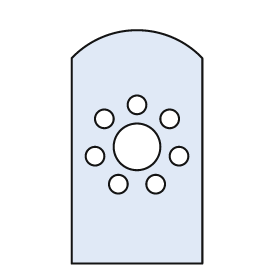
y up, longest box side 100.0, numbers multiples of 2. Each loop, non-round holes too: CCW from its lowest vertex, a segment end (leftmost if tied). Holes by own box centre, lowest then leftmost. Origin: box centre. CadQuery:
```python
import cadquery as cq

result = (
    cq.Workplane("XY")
    .moveTo(-28.0, -50.0)
    .lineTo(28.0, -50.0)
    .lineTo(28.0, 38.0)
    .threePointArc((0.0, 50.0), (-28.0, 38.0))
    .close()
    .moveTo(-8.0, -16.0)
    .circle(4.0)
    .moveTo(8.0, -16.0)
    .circle(4.0)
    .moveTo(-18.0, -4.0)
    .circle(4.0)
    .moveTo(18.0, -4.0)
    .circle(4.0)
    .moveTo(0.0, 0.0)
    .circle(10.0)
    .moveTo(-14.0, 12.0)
    .circle(4.0)
    .moveTo(14.0, 12.0)
    .circle(4.0)
    .moveTo(0.0, 18.0)
    .circle(4.0)
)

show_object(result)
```